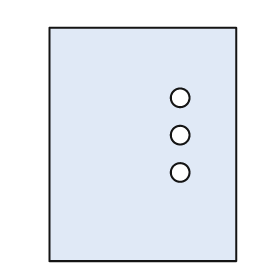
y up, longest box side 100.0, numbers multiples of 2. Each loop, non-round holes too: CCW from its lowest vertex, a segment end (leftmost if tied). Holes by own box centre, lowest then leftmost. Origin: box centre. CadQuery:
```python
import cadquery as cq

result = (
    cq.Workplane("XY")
    .moveTo(-40.0, -50.0)
    .lineTo(40.0, -50.0)
    .lineTo(40.0, 50.0)
    .lineTo(-40.0, 50.0)
    .close()
    .moveTo(16.0, -12.0)
    .circle(4.0)
    .moveTo(16.0, 4.0)
    .circle(4.0)
    .moveTo(16.0, 20.0)
    .circle(4.0)
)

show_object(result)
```